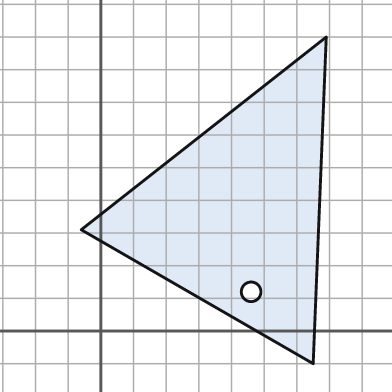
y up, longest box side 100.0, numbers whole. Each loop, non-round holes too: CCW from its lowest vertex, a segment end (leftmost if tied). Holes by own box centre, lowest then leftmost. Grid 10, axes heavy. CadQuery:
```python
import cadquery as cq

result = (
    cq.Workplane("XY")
    .moveTo(65.0, -10.0)
    .lineTo(69.0, 90.0)
    .lineTo(-6.0, 31.0)
    .close()
    .moveTo(46.0, 12.0)
    .circle(3.0)
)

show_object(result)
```